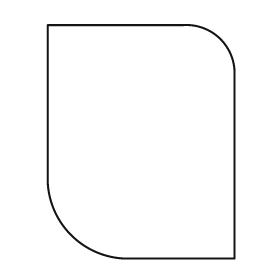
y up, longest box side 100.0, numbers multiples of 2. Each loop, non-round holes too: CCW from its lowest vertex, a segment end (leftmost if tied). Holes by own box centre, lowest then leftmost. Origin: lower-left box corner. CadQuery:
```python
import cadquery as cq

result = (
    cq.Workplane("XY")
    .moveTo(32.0, 0.0)
    .lineTo(80.0, 0.0)
    .lineTo(80.0, 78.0)
    .threePointArc((74.0, 94.0), (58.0, 100.0))
    .lineTo(0.0, 100.0)
    .lineTo(0.0, 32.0)
    .threePointArc((10.0, 10.0), (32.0, 0.0))
    .close()
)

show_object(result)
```